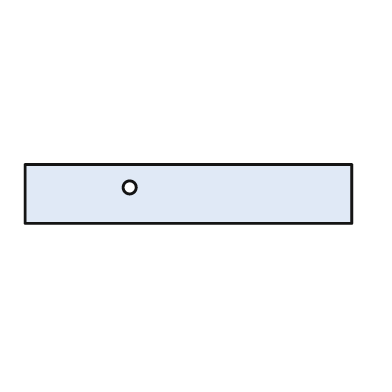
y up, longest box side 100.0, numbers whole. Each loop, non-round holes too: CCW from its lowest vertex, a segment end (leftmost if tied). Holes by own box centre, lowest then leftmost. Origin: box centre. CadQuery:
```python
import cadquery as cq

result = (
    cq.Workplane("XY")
    .moveTo(-50.0, -9.0)
    .lineTo(50.0, -9.0)
    .lineTo(50.0, 9.0)
    .lineTo(-50.0, 9.0)
    .close()
    .moveTo(-18.0, 2.0)
    .circle(2.0)
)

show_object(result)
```